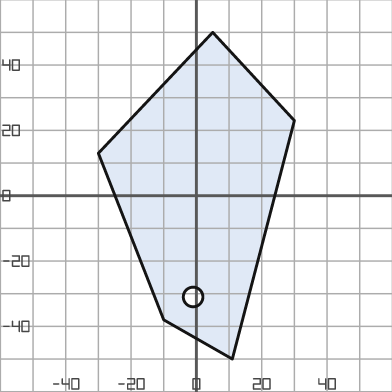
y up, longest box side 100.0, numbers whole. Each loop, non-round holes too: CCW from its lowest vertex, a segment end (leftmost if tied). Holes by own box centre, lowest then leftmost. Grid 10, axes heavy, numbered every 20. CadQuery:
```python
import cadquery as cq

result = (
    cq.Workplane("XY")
    .moveTo(11.0, -50.0)
    .lineTo(30.0, 23.0)
    .lineTo(5.0, 50.0)
    .lineTo(-30.0, 13.0)
    .lineTo(-10.0, -38.0)
    .close()
    .moveTo(-1.0, -31.0)
    .circle(3.0)
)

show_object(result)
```